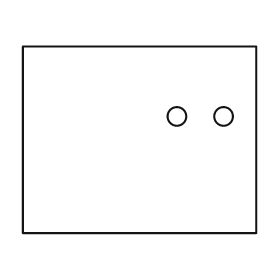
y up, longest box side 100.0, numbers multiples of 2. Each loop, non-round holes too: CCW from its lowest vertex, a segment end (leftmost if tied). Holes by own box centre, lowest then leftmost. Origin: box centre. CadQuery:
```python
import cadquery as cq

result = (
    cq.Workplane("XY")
    .moveTo(-50.0, -40.0)
    .lineTo(50.0, -40.0)
    .lineTo(50.0, 40.0)
    .lineTo(-50.0, 40.0)
    .close()
    .moveTo(16.0, 10.0)
    .circle(4.0)
    .moveTo(36.0, 10.0)
    .circle(4.0)
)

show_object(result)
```